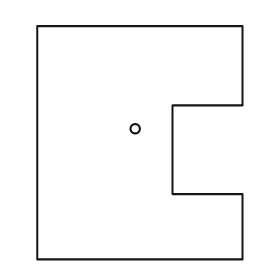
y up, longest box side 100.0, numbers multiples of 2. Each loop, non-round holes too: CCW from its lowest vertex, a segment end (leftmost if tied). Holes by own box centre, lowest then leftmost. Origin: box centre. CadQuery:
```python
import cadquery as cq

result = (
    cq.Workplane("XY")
    .moveTo(-44.0, -50.0)
    .lineTo(44.0, -50.0)
    .lineTo(44.0, -22.0)
    .lineTo(14.0, -22.0)
    .lineTo(14.0, 16.0)
    .lineTo(44.0, 16.0)
    .lineTo(44.0, 50.0)
    .lineTo(-44.0, 50.0)
    .close()
    .moveTo(-2.0, 6.0)
    .circle(2.0)
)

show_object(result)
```